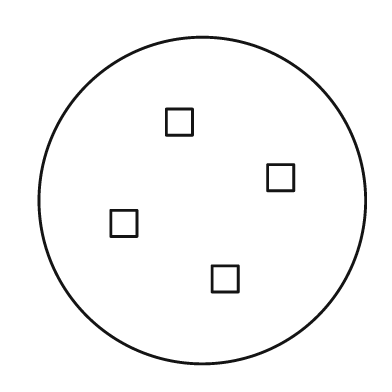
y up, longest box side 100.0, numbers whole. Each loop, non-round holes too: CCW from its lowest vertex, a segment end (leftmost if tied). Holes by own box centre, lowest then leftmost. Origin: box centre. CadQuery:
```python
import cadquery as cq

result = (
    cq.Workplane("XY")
    .moveTo(0.0, 0.0)
    .circle(50.0)
    .moveTo(3.0, -28.0)
    .lineTo(11.0, -28.0)
    .lineTo(11.0, -20.0)
    .lineTo(3.0, -20.0)
    .close()
    .moveTo(-28.0, -11.0)
    .lineTo(-20.0, -11.0)
    .lineTo(-20.0, -3.0)
    .lineTo(-28.0, -3.0)
    .close()
    .moveTo(20.0, 3.0)
    .lineTo(28.0, 3.0)
    .lineTo(28.0, 11.0)
    .lineTo(20.0, 11.0)
    .close()
    .moveTo(-11.0, 20.0)
    .lineTo(-3.0, 20.0)
    .lineTo(-3.0, 28.0)
    .lineTo(-11.0, 28.0)
    .close()
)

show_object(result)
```